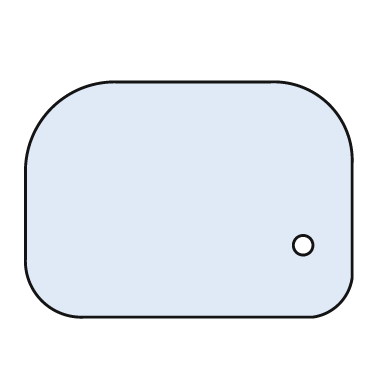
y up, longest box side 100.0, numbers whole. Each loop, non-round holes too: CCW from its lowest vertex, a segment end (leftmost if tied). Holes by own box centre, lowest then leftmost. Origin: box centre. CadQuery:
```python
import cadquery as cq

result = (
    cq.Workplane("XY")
    .moveTo(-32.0, -36.0)
    .lineTo(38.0, -36.0)
    .threePointArc((46.0, -32.0), (50.0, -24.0))
    .lineTo(50.0, 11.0)
    .threePointArc((43.0, 29.0), (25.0, 36.0))
    .lineTo(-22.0, 36.0)
    .threePointArc((-42.0, 28.0), (-50.0, 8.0))
    .lineTo(-50.0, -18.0)
    .threePointArc((-45.0, -31.0), (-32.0, -36.0))
    .close()
    .moveTo(35.0, -14.0)
    .circle(3.0)
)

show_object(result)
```